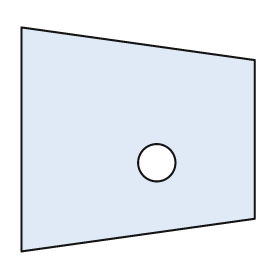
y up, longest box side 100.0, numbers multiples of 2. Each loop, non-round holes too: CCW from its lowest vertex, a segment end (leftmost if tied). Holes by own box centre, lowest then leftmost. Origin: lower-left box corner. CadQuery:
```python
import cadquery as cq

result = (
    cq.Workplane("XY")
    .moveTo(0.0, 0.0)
    .lineTo(100.0, 14.0)
    .lineTo(100.0, 82.0)
    .lineTo(0.0, 96.0)
    .close()
    .moveTo(58.0, 38.0)
    .circle(8.0)
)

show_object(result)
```